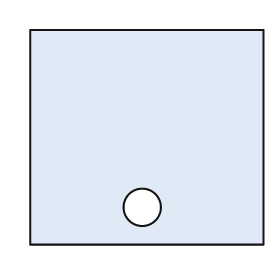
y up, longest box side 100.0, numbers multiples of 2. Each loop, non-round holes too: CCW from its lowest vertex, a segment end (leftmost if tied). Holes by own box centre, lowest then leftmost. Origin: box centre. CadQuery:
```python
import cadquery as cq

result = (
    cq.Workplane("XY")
    .moveTo(-50.0, -46.0)
    .lineTo(50.0, -46.0)
    .lineTo(50.0, 46.0)
    .lineTo(-50.0, 46.0)
    .close()
    .moveTo(-2.0, -30.0)
    .circle(8.0)
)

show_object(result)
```